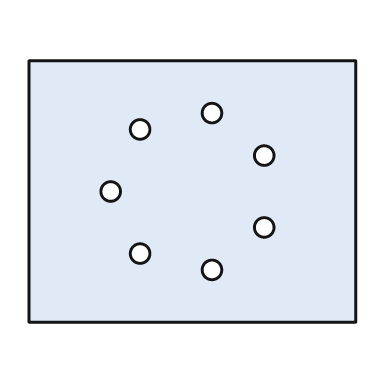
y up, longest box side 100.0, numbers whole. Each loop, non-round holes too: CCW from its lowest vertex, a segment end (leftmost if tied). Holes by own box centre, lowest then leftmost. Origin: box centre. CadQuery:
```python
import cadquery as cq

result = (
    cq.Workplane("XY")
    .moveTo(-50.0, -40.0)
    .lineTo(50.0, -40.0)
    .lineTo(50.0, 40.0)
    .lineTo(-50.0, 40.0)
    .close()
    .moveTo(6.0, -24.0)
    .circle(3.0)
    .moveTo(-16.0, -19.0)
    .circle(3.0)
    .moveTo(22.0, -11.0)
    .circle(3.0)
    .moveTo(-25.0, 0.0)
    .circle(3.0)
    .moveTo(22.0, 11.0)
    .circle(3.0)
    .moveTo(-16.0, 19.0)
    .circle(3.0)
    .moveTo(6.0, 24.0)
    .circle(3.0)
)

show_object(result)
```